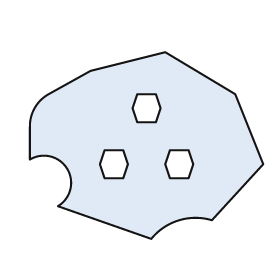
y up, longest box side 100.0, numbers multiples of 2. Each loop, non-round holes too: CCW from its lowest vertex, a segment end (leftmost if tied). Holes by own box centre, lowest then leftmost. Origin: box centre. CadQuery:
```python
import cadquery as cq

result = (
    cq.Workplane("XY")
    .moveTo(2.0, -40.0)
    .threePointArc((14.0, -32.0), (28.0, -32.0))
    .lineTo(50.0, -8.0)
    .lineTo(38.0, 22.0)
    .lineTo(8.0, 40.0)
    .lineTo(-24.0, 32.0)
    .lineTo(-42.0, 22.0)
    .threePointArc((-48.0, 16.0), (-50.0, 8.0))
    .lineTo(-50.0, -6.0)
    .threePointArc((-34.0, -10.0), (-38.0, -26.0))
    .close()
    .moveTo(-18.0, -14.0)
    .lineTo(-10.0, -14.0)
    .lineTo(-8.0, -8.0)
    .lineTo(-10.0, -2.0)
    .lineTo(-18.0, -2.0)
    .lineTo(-20.0, -8.0)
    .close()
    .moveTo(10.0, -14.0)
    .lineTo(18.0, -14.0)
    .lineTo(20.0, -8.0)
    .lineTo(18.0, -2.0)
    .lineTo(10.0, -2.0)
    .lineTo(8.0, -8.0)
    .close()
    .moveTo(-4.0, 10.0)
    .lineTo(4.0, 10.0)
    .lineTo(6.0, 16.0)
    .lineTo(4.0, 22.0)
    .lineTo(-4.0, 22.0)
    .lineTo(-6.0, 16.0)
    .close()
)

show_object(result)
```